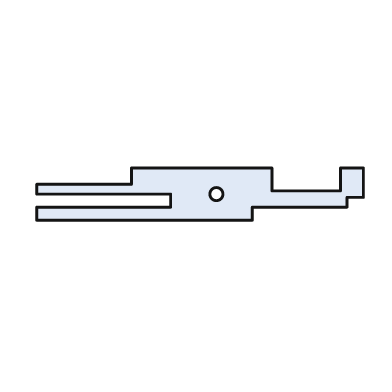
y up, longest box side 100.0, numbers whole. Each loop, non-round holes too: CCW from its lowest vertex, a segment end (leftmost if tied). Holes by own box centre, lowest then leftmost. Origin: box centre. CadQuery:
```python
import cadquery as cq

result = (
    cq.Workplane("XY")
    .moveTo(-50.0, -8.0)
    .lineTo(16.0, -8.0)
    .lineTo(16.0, -4.0)
    .lineTo(45.0, -4.0)
    .lineTo(45.0, -1.0)
    .lineTo(50.0, -1.0)
    .lineTo(50.0, 8.0)
    .lineTo(43.0, 8.0)
    .lineTo(43.0, 1.0)
    .lineTo(22.0, 1.0)
    .lineTo(22.0, 8.0)
    .lineTo(-21.0, 8.0)
    .lineTo(-21.0, 3.0)
    .lineTo(-50.0, 3.0)
    .lineTo(-50.0, 0.0)
    .lineTo(-9.0, 0.0)
    .lineTo(-9.0, -4.0)
    .lineTo(-50.0, -4.0)
    .close()
    .moveTo(5.0, 0.0)
    .circle(2.0)
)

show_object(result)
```